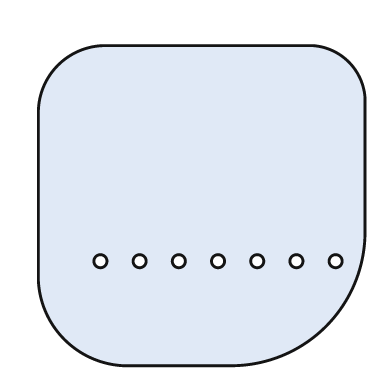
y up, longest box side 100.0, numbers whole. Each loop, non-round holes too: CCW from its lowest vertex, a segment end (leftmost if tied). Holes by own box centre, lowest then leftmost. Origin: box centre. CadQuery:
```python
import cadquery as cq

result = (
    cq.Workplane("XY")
    .moveTo(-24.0, -49.0)
    .lineTo(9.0, -49.0)
    .threePointArc((38.0, -37.0), (50.0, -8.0))
    .lineTo(50.0, 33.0)
    .threePointArc((45.0, 44.0), (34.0, 49.0))
    .lineTo(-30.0, 49.0)
    .threePointArc((-44.0, 43.0), (-50.0, 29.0))
    .lineTo(-50.0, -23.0)
    .threePointArc((-42.0, -41.0), (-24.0, -49.0))
    .close()
    .moveTo(-31.0, -17.0)
    .circle(2.0)
    .moveTo(-19.0, -17.0)
    .circle(2.0)
    .moveTo(-7.0, -17.0)
    .circle(2.0)
    .moveTo(5.0, -17.0)
    .circle(2.0)
    .moveTo(17.0, -17.0)
    .circle(2.0)
    .moveTo(29.0, -17.0)
    .circle(2.0)
    .moveTo(41.0, -17.0)
    .circle(2.0)
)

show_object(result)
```